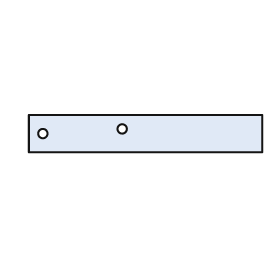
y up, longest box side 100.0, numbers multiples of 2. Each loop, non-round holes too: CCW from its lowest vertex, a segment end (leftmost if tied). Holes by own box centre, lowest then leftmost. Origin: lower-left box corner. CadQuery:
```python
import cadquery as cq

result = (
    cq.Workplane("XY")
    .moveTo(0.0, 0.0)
    .lineTo(100.0, 0.0)
    .lineTo(100.0, 16.0)
    .lineTo(0.0, 16.0)
    .close()
    .moveTo(6.0, 8.0)
    .circle(2.0)
    .moveTo(40.0, 10.0)
    .circle(2.0)
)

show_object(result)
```